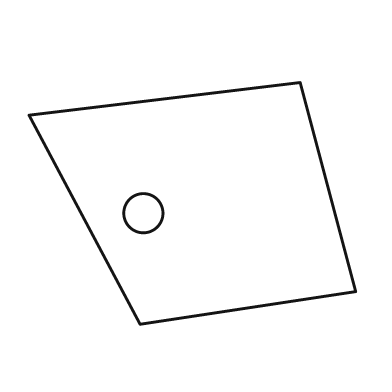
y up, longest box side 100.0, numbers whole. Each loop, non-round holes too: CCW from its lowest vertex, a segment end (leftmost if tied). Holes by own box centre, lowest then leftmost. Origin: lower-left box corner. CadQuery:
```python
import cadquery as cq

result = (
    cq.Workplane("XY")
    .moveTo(34.0, 0.0)
    .lineTo(100.0, 10.0)
    .lineTo(83.0, 74.0)
    .lineTo(0.0, 64.0)
    .close()
    .moveTo(35.0, 34.0)
    .circle(6.0)
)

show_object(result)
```